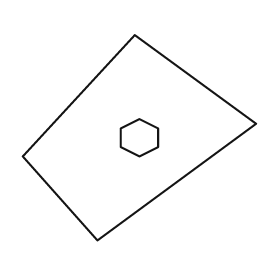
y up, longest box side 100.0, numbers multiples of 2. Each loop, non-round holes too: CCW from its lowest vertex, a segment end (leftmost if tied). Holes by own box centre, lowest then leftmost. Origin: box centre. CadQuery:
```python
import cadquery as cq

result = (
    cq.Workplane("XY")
    .moveTo(-18.0, -44.0)
    .lineTo(50.0, 6.0)
    .lineTo(-2.0, 44.0)
    .lineTo(-50.0, -8.0)
    .close()
    .moveTo(0.0, -8.0)
    .lineTo(8.0, -4.0)
    .lineTo(8.0, 4.0)
    .lineTo(0.0, 8.0)
    .lineTo(-8.0, 4.0)
    .lineTo(-8.0, -4.0)
    .close()
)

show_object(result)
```